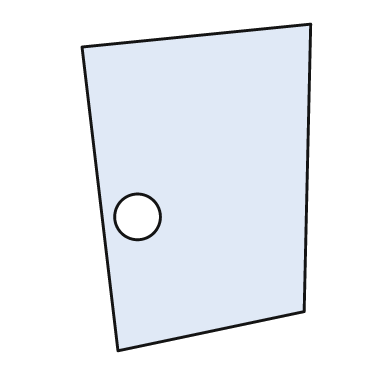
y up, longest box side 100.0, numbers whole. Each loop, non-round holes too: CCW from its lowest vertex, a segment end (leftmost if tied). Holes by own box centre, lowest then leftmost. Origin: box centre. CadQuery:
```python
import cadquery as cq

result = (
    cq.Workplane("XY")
    .moveTo(-24.0, -50.0)
    .lineTo(33.0, -38.0)
    .lineTo(35.0, 50.0)
    .lineTo(-35.0, 43.0)
    .close()
    .moveTo(-18.0, -9.0)
    .circle(7.0)
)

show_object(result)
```